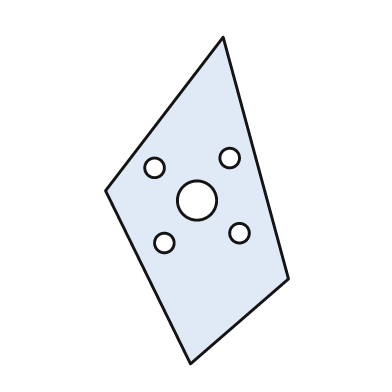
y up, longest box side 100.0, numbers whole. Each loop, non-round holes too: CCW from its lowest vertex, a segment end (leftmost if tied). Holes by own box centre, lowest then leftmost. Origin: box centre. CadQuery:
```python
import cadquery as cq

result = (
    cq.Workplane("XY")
    .moveTo(-2.0, -50.0)
    .lineTo(28.0, -24.0)
    .lineTo(8.0, 50.0)
    .lineTo(-28.0, 3.0)
    .close()
    .moveTo(-10.0, -13.0)
    .circle(3.0)
    .moveTo(13.0, -10.0)
    .circle(3.0)
    .moveTo(0.0, 0.0)
    .circle(6.0)
    .moveTo(-13.0, 10.0)
    .circle(3.0)
    .moveTo(10.0, 13.0)
    .circle(3.0)
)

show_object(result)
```